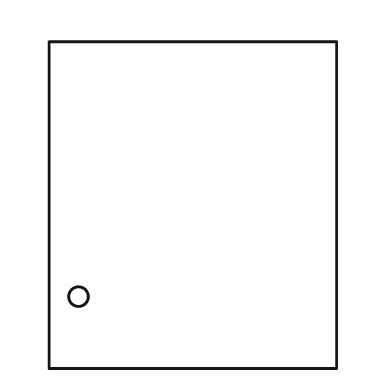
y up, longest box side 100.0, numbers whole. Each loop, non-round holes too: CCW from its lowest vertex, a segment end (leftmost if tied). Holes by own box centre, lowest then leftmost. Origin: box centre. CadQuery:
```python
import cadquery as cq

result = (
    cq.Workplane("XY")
    .moveTo(-44.0, -50.0)
    .lineTo(44.0, -50.0)
    .lineTo(44.0, 50.0)
    .lineTo(-44.0, 50.0)
    .close()
    .moveTo(-35.0, -28.0)
    .circle(3.0)
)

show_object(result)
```